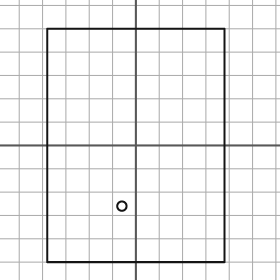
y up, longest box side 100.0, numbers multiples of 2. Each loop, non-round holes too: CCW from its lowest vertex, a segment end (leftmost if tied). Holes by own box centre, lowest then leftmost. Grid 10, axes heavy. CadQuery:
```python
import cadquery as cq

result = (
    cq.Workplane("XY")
    .moveTo(-38.0, -50.0)
    .lineTo(38.0, -50.0)
    .lineTo(38.0, 50.0)
    .lineTo(-38.0, 50.0)
    .close()
    .moveTo(-6.0, -26.0)
    .circle(2.0)
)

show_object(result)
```